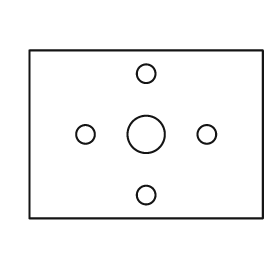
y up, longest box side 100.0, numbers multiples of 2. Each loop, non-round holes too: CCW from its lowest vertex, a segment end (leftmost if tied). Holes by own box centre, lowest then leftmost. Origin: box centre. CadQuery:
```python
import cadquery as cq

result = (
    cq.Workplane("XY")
    .moveTo(-50.0, -36.0)
    .lineTo(50.0, -36.0)
    .lineTo(50.0, 36.0)
    .lineTo(-50.0, 36.0)
    .close()
    .moveTo(0.0, -26.0)
    .circle(4.0)
    .moveTo(-26.0, 0.0)
    .circle(4.0)
    .moveTo(0.0, 0.0)
    .circle(8.0)
    .moveTo(26.0, 0.0)
    .circle(4.0)
    .moveTo(0.0, 26.0)
    .circle(4.0)
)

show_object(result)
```